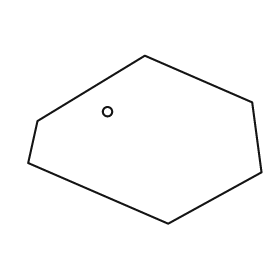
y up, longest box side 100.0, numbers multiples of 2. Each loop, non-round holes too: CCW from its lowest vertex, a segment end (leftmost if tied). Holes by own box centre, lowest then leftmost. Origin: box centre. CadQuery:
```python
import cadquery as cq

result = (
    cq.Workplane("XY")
    .moveTo(10.0, -36.0)
    .lineTo(50.0, -14.0)
    .lineTo(46.0, 16.0)
    .lineTo(0.0, 36.0)
    .lineTo(-46.0, 8.0)
    .lineTo(-50.0, -10.0)
    .close()
    .moveTo(-16.0, 12.0)
    .circle(2.0)
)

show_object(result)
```